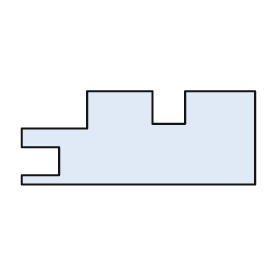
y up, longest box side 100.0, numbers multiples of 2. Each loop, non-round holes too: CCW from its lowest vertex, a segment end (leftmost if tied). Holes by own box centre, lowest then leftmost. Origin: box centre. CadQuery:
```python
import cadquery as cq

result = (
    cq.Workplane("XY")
    .moveTo(-50.0, -20.0)
    .lineTo(50.0, -20.0)
    .lineTo(50.0, 20.0)
    .lineTo(20.0, 20.0)
    .lineTo(20.0, 6.0)
    .lineTo(6.0, 6.0)
    .lineTo(6.0, 20.0)
    .lineTo(-22.0, 20.0)
    .lineTo(-22.0, 4.0)
    .lineTo(-50.0, 4.0)
    .lineTo(-50.0, -4.0)
    .lineTo(-34.0, -4.0)
    .lineTo(-34.0, -16.0)
    .lineTo(-50.0, -16.0)
    .close()
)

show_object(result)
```